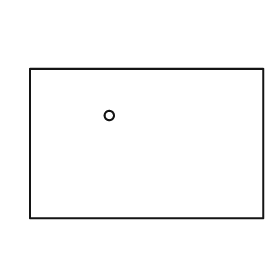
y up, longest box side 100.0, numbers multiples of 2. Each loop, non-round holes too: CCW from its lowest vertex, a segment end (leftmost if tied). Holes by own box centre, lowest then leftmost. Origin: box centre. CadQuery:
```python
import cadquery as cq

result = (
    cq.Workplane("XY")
    .moveTo(-50.0, -32.0)
    .lineTo(50.0, -32.0)
    .lineTo(50.0, 32.0)
    .lineTo(-50.0, 32.0)
    .close()
    .moveTo(-16.0, 12.0)
    .circle(2.0)
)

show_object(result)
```